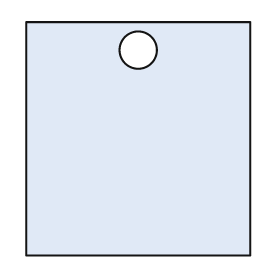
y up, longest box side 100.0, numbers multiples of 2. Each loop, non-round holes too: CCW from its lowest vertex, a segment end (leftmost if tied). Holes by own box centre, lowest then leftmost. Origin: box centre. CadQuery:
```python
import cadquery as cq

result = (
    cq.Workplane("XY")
    .moveTo(-48.0, -50.0)
    .lineTo(48.0, -50.0)
    .lineTo(48.0, 50.0)
    .lineTo(-48.0, 50.0)
    .close()
    .moveTo(0.0, 38.0)
    .circle(8.0)
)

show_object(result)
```